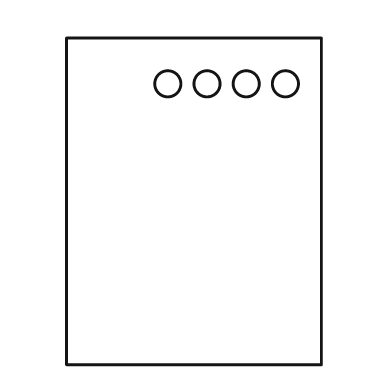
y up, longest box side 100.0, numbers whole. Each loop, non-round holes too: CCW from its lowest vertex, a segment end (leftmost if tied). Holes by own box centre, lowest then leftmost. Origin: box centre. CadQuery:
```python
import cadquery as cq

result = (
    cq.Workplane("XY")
    .moveTo(-39.0, -50.0)
    .lineTo(39.0, -50.0)
    .lineTo(39.0, 50.0)
    .lineTo(-39.0, 50.0)
    .close()
    .moveTo(-8.0, 36.0)
    .circle(4.0)
    .moveTo(4.0, 36.0)
    .circle(4.0)
    .moveTo(16.0, 36.0)
    .circle(4.0)
    .moveTo(28.0, 36.0)
    .circle(4.0)
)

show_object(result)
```